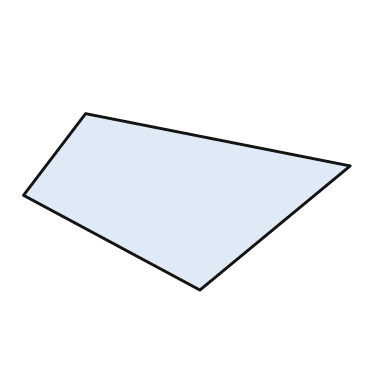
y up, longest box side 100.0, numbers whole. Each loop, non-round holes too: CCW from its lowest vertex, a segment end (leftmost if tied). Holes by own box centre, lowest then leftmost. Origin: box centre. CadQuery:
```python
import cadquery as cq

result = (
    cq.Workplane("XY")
    .moveTo(4.0, -27.0)
    .lineTo(50.0, 11.0)
    .lineTo(-31.0, 27.0)
    .lineTo(-50.0, 2.0)
    .close()
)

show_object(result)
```